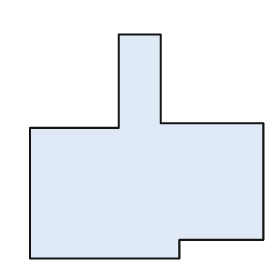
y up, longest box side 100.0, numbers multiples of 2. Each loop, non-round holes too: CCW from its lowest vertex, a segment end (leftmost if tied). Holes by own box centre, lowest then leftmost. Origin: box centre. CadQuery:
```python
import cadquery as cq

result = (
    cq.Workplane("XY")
    .moveTo(-50.0, -48.0)
    .lineTo(14.0, -48.0)
    .lineTo(14.0, -40.0)
    .lineTo(50.0, -40.0)
    .lineTo(50.0, 10.0)
    .lineTo(6.0, 10.0)
    .lineTo(6.0, 48.0)
    .lineTo(-12.0, 48.0)
    .lineTo(-12.0, 8.0)
    .lineTo(-50.0, 8.0)
    .close()
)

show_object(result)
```